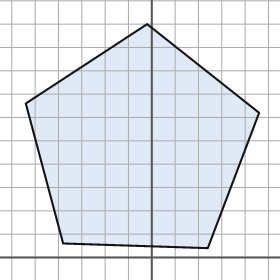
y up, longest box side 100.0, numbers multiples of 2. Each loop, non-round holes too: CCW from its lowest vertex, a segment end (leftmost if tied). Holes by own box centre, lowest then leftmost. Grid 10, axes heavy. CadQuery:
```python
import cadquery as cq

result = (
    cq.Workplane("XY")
    .moveTo(24.0, 4.0)
    .lineTo(46.0, 62.0)
    .lineTo(-2.0, 100.0)
    .lineTo(-54.0, 66.0)
    .lineTo(-38.0, 6.0)
    .close()
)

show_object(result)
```